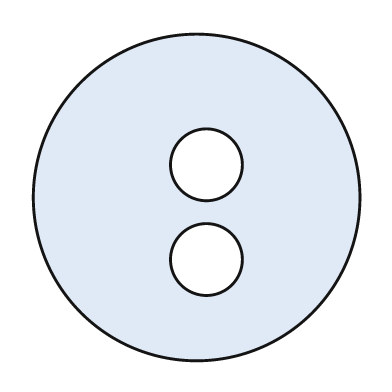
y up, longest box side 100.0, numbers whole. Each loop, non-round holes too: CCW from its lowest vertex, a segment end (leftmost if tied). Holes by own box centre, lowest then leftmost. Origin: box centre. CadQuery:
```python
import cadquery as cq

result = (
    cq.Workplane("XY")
    .moveTo(0.0, 0.0)
    .circle(50.0)
    .moveTo(3.0, -19.0)
    .circle(11.0)
    .moveTo(3.0, 10.0)
    .circle(11.0)
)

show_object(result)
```